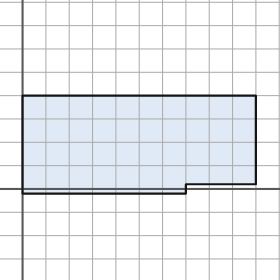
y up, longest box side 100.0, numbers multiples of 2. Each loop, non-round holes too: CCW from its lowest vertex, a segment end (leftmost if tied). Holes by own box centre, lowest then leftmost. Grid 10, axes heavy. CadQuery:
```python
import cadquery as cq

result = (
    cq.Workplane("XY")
    .moveTo(0.0, -2.0)
    .lineTo(70.0, -2.0)
    .lineTo(70.0, 2.0)
    .lineTo(100.0, 2.0)
    .lineTo(100.0, 40.0)
    .lineTo(0.0, 40.0)
    .close()
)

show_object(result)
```